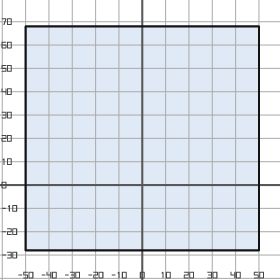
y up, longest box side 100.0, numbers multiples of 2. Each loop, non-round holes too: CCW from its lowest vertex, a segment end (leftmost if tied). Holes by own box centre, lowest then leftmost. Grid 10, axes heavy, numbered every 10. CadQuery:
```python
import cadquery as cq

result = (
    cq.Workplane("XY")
    .moveTo(-50.0, -28.0)
    .lineTo(50.0, -28.0)
    .lineTo(50.0, 68.0)
    .lineTo(-50.0, 68.0)
    .close()
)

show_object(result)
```